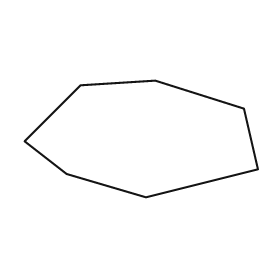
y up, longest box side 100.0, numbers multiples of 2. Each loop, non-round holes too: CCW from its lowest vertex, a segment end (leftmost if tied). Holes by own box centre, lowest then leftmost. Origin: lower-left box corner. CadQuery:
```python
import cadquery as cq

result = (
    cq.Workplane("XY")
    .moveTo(52.0, 0.0)
    .lineTo(100.0, 12.0)
    .lineTo(94.0, 38.0)
    .lineTo(56.0, 50.0)
    .lineTo(24.0, 48.0)
    .lineTo(0.0, 24.0)
    .lineTo(18.0, 10.0)
    .close()
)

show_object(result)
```